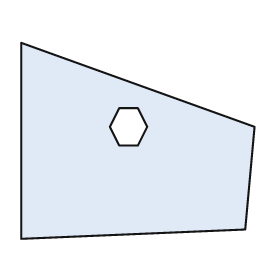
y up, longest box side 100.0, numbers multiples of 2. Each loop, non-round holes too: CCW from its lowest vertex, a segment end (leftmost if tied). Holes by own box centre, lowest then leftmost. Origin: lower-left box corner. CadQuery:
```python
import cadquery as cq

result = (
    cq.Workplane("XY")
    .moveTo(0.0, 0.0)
    .lineTo(96.0, 4.0)
    .lineTo(100.0, 48.0)
    .lineTo(0.0, 84.0)
    .close()
    .moveTo(42.0, 40.0)
    .lineTo(50.0, 40.0)
    .lineTo(54.0, 48.0)
    .lineTo(50.0, 56.0)
    .lineTo(42.0, 56.0)
    .lineTo(38.0, 48.0)
    .close()
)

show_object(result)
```